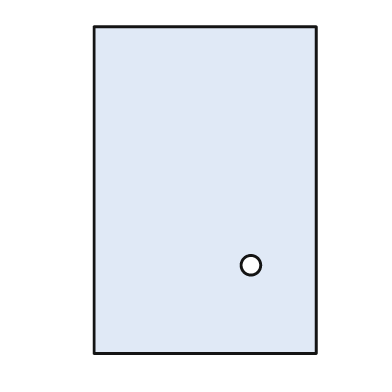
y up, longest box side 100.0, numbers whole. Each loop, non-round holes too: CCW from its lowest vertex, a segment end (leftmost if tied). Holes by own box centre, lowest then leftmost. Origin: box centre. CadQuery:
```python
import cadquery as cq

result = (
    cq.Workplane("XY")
    .moveTo(-34.0, -50.0)
    .lineTo(34.0, -50.0)
    .lineTo(34.0, 50.0)
    .lineTo(-34.0, 50.0)
    .close()
    .moveTo(14.0, -23.0)
    .circle(3.0)
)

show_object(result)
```